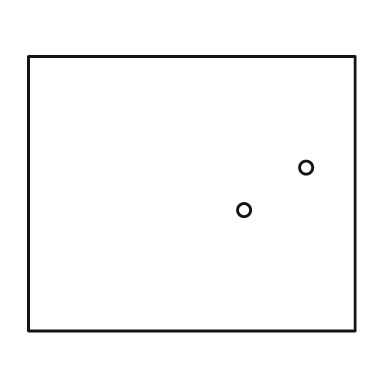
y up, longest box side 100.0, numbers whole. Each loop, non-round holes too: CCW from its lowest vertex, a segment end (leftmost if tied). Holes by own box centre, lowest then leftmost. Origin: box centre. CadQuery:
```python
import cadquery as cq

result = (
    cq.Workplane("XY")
    .moveTo(-50.0, -42.0)
    .lineTo(50.0, -42.0)
    .lineTo(50.0, 42.0)
    .lineTo(-50.0, 42.0)
    .close()
    .moveTo(16.0, -5.0)
    .circle(2.0)
    .moveTo(35.0, 8.0)
    .circle(2.0)
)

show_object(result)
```